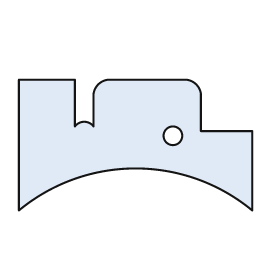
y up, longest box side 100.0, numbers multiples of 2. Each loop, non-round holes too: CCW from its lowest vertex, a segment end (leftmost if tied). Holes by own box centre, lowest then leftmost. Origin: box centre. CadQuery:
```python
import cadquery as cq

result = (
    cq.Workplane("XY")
    .moveTo(-50.0, -28.0)
    .threePointArc((0.0, -10.0), (50.0, -28.0))
    .lineTo(50.0, 6.0)
    .lineTo(28.0, 6.0)
    .lineTo(28.0, 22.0)
    .threePointArc((26.0, 26.0), (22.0, 28.0))
    .lineTo(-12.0, 28.0)
    .threePointArc((-16.0, 26.0), (-18.0, 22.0))
    .lineTo(-18.0, 8.0)
    .threePointArc((-22.0, 10.0), (-26.0, 8.0))
    .lineTo(-26.0, 28.0)
    .lineTo(-50.0, 28.0)
    .close()
    .moveTo(16.0, 4.0)
    .circle(4.0)
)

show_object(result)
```